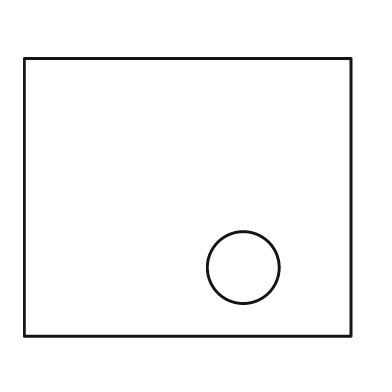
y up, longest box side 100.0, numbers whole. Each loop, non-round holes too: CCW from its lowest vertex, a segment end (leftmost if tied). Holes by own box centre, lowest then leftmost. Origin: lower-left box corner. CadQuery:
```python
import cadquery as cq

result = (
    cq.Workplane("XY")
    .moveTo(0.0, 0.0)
    .lineTo(100.0, 0.0)
    .lineTo(100.0, 85.0)
    .lineTo(0.0, 85.0)
    .close()
    .moveTo(67.0, 21.0)
    .circle(11.0)
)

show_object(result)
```